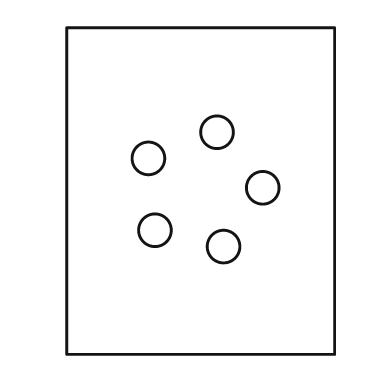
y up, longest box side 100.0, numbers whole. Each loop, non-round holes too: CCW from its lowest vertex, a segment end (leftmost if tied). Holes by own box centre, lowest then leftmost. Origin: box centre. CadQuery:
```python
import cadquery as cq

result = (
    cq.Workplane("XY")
    .moveTo(-41.0, -50.0)
    .lineTo(41.0, -50.0)
    .lineTo(41.0, 50.0)
    .lineTo(-41.0, 50.0)
    .close()
    .moveTo(7.0, -17.0)
    .circle(5.0)
    .moveTo(-14.0, -12.0)
    .circle(5.0)
    .moveTo(19.0, 1.0)
    .circle(5.0)
    .moveTo(-16.0, 10.0)
    .circle(5.0)
    .moveTo(5.0, 18.0)
    .circle(5.0)
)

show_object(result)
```